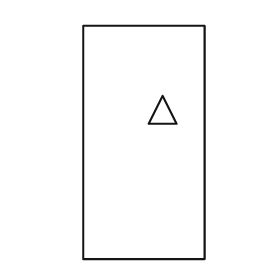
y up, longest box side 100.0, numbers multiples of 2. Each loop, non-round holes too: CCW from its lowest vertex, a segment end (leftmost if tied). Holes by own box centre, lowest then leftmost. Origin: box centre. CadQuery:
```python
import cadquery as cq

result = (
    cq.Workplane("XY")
    .moveTo(-26.0, -50.0)
    .lineTo(26.0, -50.0)
    .lineTo(26.0, 50.0)
    .lineTo(-26.0, 50.0)
    .close()
    .moveTo(2.0, 8.0)
    .lineTo(14.0, 8.0)
    .lineTo(8.0, 20.0)
    .close()
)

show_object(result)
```